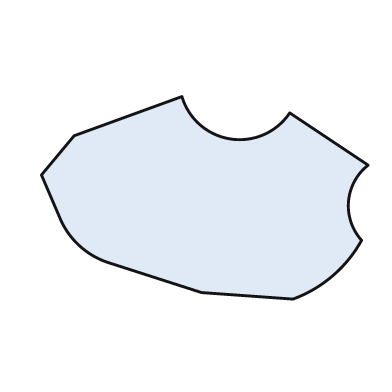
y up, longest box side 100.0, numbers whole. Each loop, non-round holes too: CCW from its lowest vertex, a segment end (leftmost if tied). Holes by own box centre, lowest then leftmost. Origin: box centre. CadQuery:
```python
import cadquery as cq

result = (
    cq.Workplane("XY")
    .moveTo(27.0, -31.0)
    .threePointArc((39.0, -24.0), (48.0, -13.0))
    .threePointArc((44.0, -1.0), (50.0, 10.0))
    .lineTo(26.0, 26.0)
    .threePointArc((8.0, 18.0), (-7.0, 31.0))
    .lineTo(-40.0, 19.0)
    .lineTo(-50.0, 7.0)
    .lineTo(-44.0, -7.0)
    .threePointArc((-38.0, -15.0), (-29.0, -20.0))
    .lineTo(-1.0, -29.0)
    .close()
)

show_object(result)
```